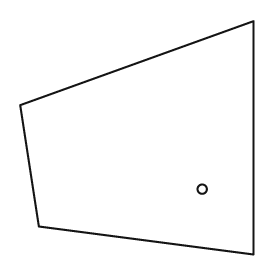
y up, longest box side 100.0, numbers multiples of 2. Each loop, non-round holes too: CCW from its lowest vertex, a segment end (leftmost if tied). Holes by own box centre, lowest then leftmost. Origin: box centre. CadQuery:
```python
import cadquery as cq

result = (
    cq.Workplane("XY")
    .moveTo(50.0, -50.0)
    .lineTo(50.0, 50.0)
    .lineTo(-50.0, 14.0)
    .lineTo(-42.0, -38.0)
    .close()
    .moveTo(28.0, -22.0)
    .circle(2.0)
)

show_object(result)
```